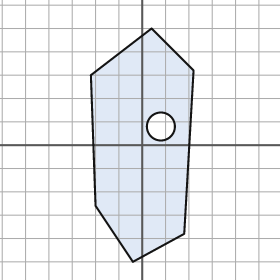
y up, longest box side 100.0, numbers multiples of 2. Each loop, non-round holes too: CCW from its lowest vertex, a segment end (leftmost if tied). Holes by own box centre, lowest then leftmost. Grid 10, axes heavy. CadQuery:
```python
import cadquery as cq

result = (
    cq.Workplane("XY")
    .moveTo(-4.0, -50.0)
    .lineTo(18.0, -38.0)
    .lineTo(22.0, 32.0)
    .lineTo(4.0, 50.0)
    .lineTo(-22.0, 30.0)
    .lineTo(-20.0, -26.0)
    .close()
    .moveTo(8.0, 8.0)
    .circle(6.0)
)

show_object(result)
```